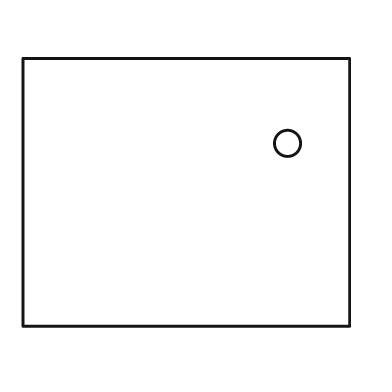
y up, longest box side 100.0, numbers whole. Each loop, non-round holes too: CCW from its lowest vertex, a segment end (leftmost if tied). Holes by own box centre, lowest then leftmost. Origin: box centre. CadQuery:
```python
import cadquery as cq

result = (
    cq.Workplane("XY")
    .moveTo(-50.0, -41.0)
    .lineTo(50.0, -41.0)
    .lineTo(50.0, 41.0)
    .lineTo(-50.0, 41.0)
    .close()
    .moveTo(31.0, 15.0)
    .circle(4.0)
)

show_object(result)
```